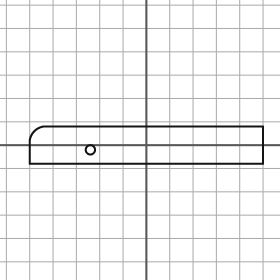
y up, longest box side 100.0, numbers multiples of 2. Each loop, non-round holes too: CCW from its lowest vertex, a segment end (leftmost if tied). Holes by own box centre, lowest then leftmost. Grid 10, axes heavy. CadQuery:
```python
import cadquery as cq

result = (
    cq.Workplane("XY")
    .moveTo(-50.0, -8.0)
    .lineTo(50.0, -8.0)
    .lineTo(50.0, 8.0)
    .lineTo(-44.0, 8.0)
    .threePointArc((-48.0, 6.0), (-50.0, 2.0))
    .close()
    .moveTo(-24.0, -2.0)
    .circle(2.0)
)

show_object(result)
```